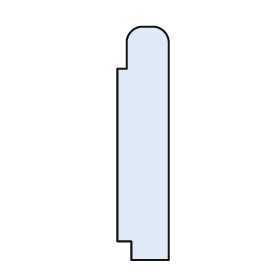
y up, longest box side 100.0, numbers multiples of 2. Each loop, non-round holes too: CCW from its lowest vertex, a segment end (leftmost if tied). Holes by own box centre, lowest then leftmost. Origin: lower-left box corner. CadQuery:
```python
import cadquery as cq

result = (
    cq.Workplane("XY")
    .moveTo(6.0, 0.0)
    .lineTo(22.0, 0.0)
    .lineTo(22.0, 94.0)
    .threePointArc((20.0, 98.0), (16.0, 100.0))
    .lineTo(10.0, 100.0)
    .threePointArc((6.0, 98.0), (4.0, 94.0))
    .lineTo(4.0, 82.0)
    .lineTo(0.0, 82.0)
    .lineTo(0.0, 8.0)
    .lineTo(6.0, 8.0)
    .close()
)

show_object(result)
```